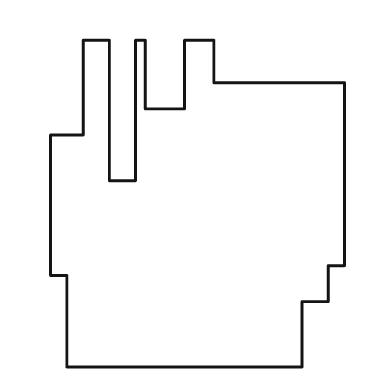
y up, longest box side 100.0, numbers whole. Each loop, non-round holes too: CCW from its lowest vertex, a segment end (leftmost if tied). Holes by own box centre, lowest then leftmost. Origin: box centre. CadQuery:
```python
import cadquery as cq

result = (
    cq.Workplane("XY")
    .moveTo(-40.0, -50.0)
    .lineTo(32.0, -50.0)
    .lineTo(32.0, -30.0)
    .lineTo(40.0, -30.0)
    .lineTo(40.0, -19.0)
    .lineTo(45.0, -19.0)
    .lineTo(45.0, 37.0)
    .lineTo(5.0, 37.0)
    .lineTo(5.0, 50.0)
    .lineTo(-4.0, 50.0)
    .lineTo(-4.0, 29.0)
    .lineTo(-16.0, 29.0)
    .lineTo(-16.0, 50.0)
    .lineTo(-19.0, 50.0)
    .lineTo(-19.0, 7.0)
    .lineTo(-27.0, 7.0)
    .lineTo(-27.0, 50.0)
    .lineTo(-35.0, 50.0)
    .lineTo(-35.0, 21.0)
    .lineTo(-45.0, 21.0)
    .lineTo(-45.0, -22.0)
    .lineTo(-40.0, -22.0)
    .close()
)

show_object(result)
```